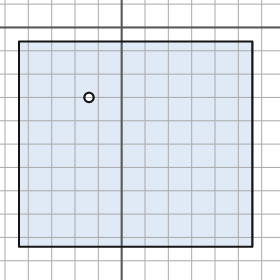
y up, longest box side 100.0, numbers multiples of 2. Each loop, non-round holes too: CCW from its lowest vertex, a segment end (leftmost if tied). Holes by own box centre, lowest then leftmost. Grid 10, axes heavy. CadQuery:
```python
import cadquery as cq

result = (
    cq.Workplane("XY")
    .moveTo(-44.0, -94.0)
    .lineTo(56.0, -94.0)
    .lineTo(56.0, -6.0)
    .lineTo(-44.0, -6.0)
    .close()
    .moveTo(-14.0, -30.0)
    .circle(2.0)
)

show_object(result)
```